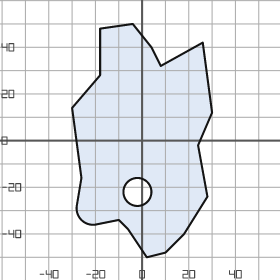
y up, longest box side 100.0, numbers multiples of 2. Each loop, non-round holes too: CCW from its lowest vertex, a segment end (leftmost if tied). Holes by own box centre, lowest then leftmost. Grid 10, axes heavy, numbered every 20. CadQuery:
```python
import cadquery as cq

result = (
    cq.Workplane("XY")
    .moveTo(2.0, -50.0)
    .lineTo(10.0, -48.0)
    .lineTo(18.0, -40.0)
    .lineTo(28.0, -24.0)
    .lineTo(24.0, -2.0)
    .lineTo(30.0, 12.0)
    .lineTo(26.0, 42.0)
    .lineTo(8.0, 32.0)
    .lineTo(4.0, 40.0)
    .lineTo(-4.0, 50.0)
    .lineTo(-18.0, 48.0)
    .lineTo(-18.0, 28.0)
    .lineTo(-30.0, 14.0)
    .lineTo(-26.0, -16.0)
    .lineTo(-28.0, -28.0)
    .threePointArc((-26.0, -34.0), (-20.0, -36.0))
    .lineTo(-10.0, -34.0)
    .lineTo(-6.0, -38.0)
    .close()
    .moveTo(-2.0, -22.0)
    .circle(6.0)
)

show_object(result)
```